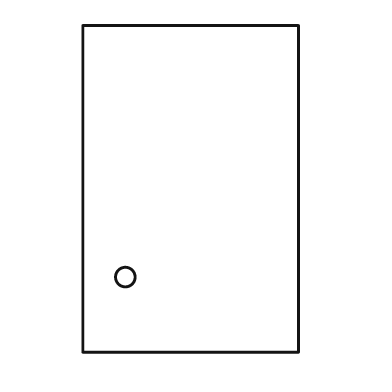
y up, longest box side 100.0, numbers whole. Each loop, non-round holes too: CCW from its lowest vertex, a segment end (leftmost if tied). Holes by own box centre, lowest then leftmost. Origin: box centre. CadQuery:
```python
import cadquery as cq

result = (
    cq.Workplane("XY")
    .moveTo(-33.0, -50.0)
    .lineTo(33.0, -50.0)
    .lineTo(33.0, 50.0)
    .lineTo(-33.0, 50.0)
    .close()
    .moveTo(-20.0, -27.0)
    .circle(3.0)
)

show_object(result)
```